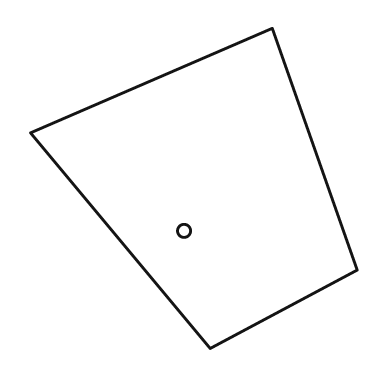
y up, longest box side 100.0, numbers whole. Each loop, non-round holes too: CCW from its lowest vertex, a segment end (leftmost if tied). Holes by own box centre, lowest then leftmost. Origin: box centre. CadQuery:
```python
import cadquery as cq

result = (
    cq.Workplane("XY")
    .moveTo(5.0, -49.0)
    .lineTo(50.0, -25.0)
    .lineTo(24.0, 49.0)
    .lineTo(-50.0, 17.0)
    .close()
    .moveTo(-3.0, -13.0)
    .circle(2.0)
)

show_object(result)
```